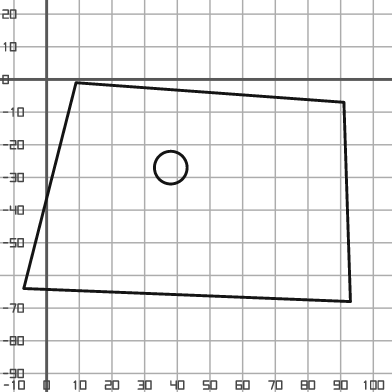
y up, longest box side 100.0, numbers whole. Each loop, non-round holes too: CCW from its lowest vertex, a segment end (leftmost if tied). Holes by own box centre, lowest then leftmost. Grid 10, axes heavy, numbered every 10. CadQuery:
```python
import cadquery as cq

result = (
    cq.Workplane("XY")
    .moveTo(93.0, -68.0)
    .lineTo(91.0, -7.0)
    .lineTo(9.0, -1.0)
    .lineTo(-7.0, -64.0)
    .close()
    .moveTo(38.0, -27.0)
    .circle(5.0)
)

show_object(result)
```